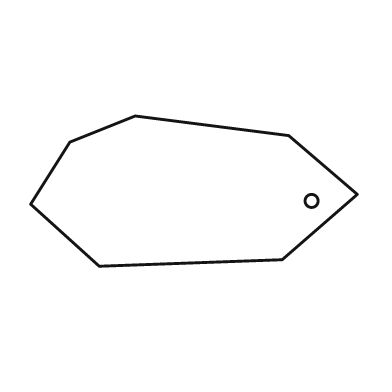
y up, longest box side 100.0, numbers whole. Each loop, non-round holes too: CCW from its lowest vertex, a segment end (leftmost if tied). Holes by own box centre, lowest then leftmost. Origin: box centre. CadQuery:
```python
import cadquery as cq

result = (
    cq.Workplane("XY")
    .moveTo(-29.0, -23.0)
    .lineTo(27.0, -21.0)
    .lineTo(50.0, -1.0)
    .lineTo(29.0, 17.0)
    .lineTo(-18.0, 23.0)
    .lineTo(-38.0, 15.0)
    .lineTo(-50.0, -4.0)
    .close()
    .moveTo(36.0, -3.0)
    .circle(2.0)
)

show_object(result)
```